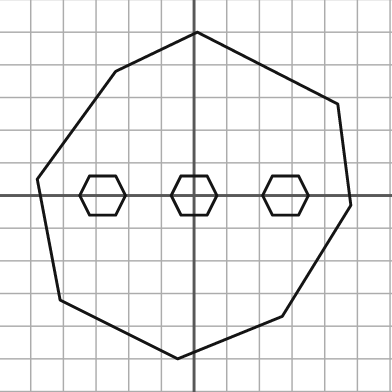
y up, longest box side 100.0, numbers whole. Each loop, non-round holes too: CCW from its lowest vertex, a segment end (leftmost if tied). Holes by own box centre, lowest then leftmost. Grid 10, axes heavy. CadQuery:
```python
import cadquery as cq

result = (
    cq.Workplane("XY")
    .moveTo(-5.0, -50.0)
    .lineTo(27.0, -37.0)
    .lineTo(48.0, -3.0)
    .lineTo(44.0, 28.0)
    .lineTo(1.0, 50.0)
    .lineTo(-24.0, 38.0)
    .lineTo(-48.0, 5.0)
    .lineTo(-41.0, -32.0)
    .close()
    .moveTo(-32.0, -6.0)
    .lineTo(-24.0, -6.0)
    .lineTo(-21.0, 0.0)
    .lineTo(-24.0, 6.0)
    .lineTo(-32.0, 6.0)
    .lineTo(-35.0, 0.0)
    .close()
    .moveTo(-4.0, -6.0)
    .lineTo(4.0, -6.0)
    .lineTo(7.0, 0.0)
    .lineTo(4.0, 6.0)
    .lineTo(-4.0, 6.0)
    .lineTo(-7.0, 0.0)
    .close()
    .moveTo(24.0, -6.0)
    .lineTo(32.0, -6.0)
    .lineTo(35.0, 0.0)
    .lineTo(32.0, 6.0)
    .lineTo(24.0, 6.0)
    .lineTo(21.0, 0.0)
    .close()
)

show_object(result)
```